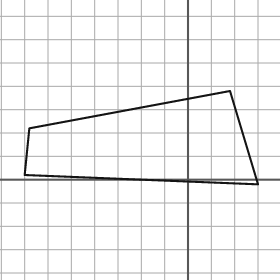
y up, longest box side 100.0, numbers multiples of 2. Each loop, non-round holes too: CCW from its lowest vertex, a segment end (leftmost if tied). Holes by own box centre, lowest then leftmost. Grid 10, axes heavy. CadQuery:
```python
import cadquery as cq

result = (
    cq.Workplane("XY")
    .moveTo(30.0, -2.0)
    .lineTo(18.0, 38.0)
    .lineTo(-68.0, 22.0)
    .lineTo(-70.0, 2.0)
    .close()
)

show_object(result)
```